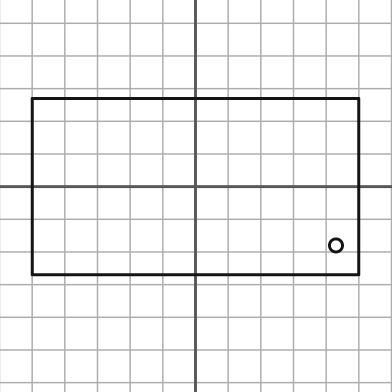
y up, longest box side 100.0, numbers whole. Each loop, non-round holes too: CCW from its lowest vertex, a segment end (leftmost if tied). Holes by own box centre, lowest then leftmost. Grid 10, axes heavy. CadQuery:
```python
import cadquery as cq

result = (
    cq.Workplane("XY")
    .moveTo(-50.0, -27.0)
    .lineTo(50.0, -27.0)
    .lineTo(50.0, 27.0)
    .lineTo(-50.0, 27.0)
    .close()
    .moveTo(43.0, -18.0)
    .circle(2.0)
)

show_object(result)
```